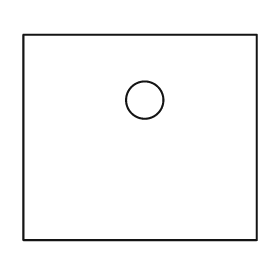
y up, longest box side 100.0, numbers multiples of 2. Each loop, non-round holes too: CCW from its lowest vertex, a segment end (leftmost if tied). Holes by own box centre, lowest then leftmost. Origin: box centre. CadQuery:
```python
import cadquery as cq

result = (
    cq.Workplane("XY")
    .moveTo(-50.0, -44.0)
    .lineTo(50.0, -44.0)
    .lineTo(50.0, 44.0)
    .lineTo(-50.0, 44.0)
    .close()
    .moveTo(2.0, 16.0)
    .circle(8.0)
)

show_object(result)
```